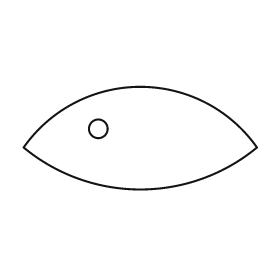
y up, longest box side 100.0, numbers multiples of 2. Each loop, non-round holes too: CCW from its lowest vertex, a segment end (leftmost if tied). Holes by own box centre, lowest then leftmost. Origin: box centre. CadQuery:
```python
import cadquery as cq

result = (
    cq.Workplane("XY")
    .moveTo(-50.0, -4.0)
    .threePointArc((0.0, -22.0), (50.0, -4.0))
    .threePointArc((0.0, 22.0), (-50.0, -4.0))
    .close()
    .moveTo(-18.0, 4.0)
    .circle(4.0)
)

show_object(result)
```